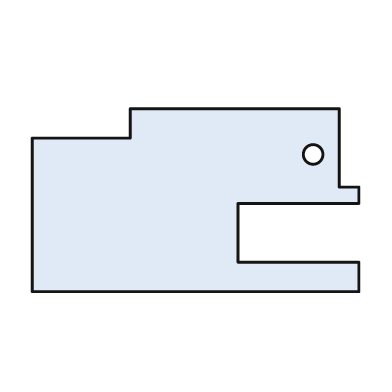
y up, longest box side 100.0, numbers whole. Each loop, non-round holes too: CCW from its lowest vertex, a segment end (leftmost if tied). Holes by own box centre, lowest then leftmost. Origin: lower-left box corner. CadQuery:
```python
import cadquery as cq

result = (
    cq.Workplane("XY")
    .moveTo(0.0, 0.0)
    .lineTo(100.0, 0.0)
    .lineTo(100.0, 9.0)
    .lineTo(63.0, 9.0)
    .lineTo(63.0, 27.0)
    .lineTo(100.0, 27.0)
    .lineTo(100.0, 32.0)
    .lineTo(94.0, 32.0)
    .lineTo(94.0, 56.0)
    .lineTo(30.0, 56.0)
    .lineTo(30.0, 47.0)
    .lineTo(0.0, 47.0)
    .close()
    .moveTo(86.0, 42.0)
    .circle(3.0)
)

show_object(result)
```